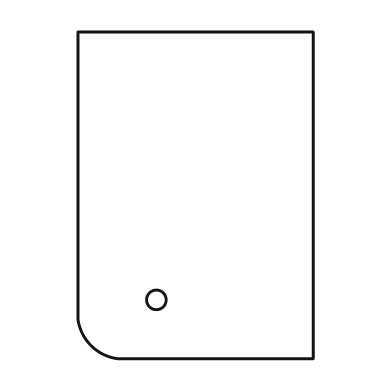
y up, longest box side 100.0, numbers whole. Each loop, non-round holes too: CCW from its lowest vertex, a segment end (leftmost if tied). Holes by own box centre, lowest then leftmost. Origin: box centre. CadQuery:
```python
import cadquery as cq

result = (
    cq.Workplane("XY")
    .moveTo(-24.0, -50.0)
    .lineTo(36.0, -50.0)
    .lineTo(36.0, 50.0)
    .lineTo(-36.0, 50.0)
    .lineTo(-36.0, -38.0)
    .threePointArc((-32.0, -46.0), (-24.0, -50.0))
    .close()
    .moveTo(-12.0, -32.0)
    .circle(3.0)
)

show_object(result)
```